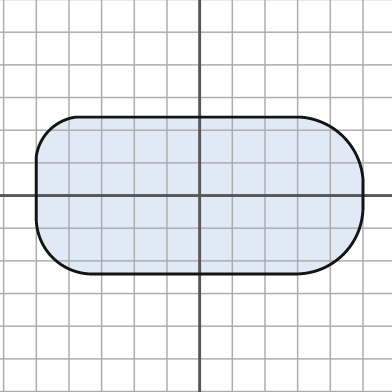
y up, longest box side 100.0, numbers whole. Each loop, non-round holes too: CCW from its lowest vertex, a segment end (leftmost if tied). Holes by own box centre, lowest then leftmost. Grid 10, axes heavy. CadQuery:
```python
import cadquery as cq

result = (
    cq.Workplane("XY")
    .moveTo(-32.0, -24.0)
    .lineTo(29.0, -24.0)
    .threePointArc((44.0, -18.0), (50.0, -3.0))
    .lineTo(50.0, 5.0)
    .threePointArc((44.0, 18.0), (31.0, 24.0))
    .lineTo(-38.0, 24.0)
    .threePointArc((-46.0, 20.0), (-50.0, 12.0))
    .lineTo(-50.0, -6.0)
    .threePointArc((-45.0, -19.0), (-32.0, -24.0))
    .close()
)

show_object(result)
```